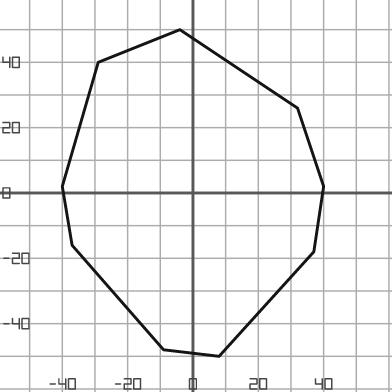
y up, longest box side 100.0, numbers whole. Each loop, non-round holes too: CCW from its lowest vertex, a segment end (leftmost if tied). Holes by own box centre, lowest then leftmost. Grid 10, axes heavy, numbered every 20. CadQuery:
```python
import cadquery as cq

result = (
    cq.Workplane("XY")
    .moveTo(8.0, -50.0)
    .lineTo(37.0, -18.0)
    .lineTo(40.0, 2.0)
    .lineTo(32.0, 26.0)
    .lineTo(-4.0, 50.0)
    .lineTo(-29.0, 40.0)
    .lineTo(-40.0, 2.0)
    .lineTo(-37.0, -16.0)
    .lineTo(-9.0, -48.0)
    .close()
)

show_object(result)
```